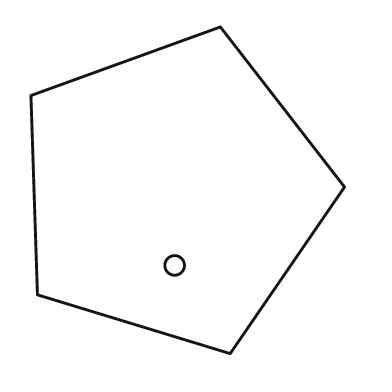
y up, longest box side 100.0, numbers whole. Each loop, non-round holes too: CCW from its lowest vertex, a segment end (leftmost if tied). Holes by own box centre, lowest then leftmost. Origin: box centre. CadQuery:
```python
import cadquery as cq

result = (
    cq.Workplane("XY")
    .moveTo(13.0, -50.0)
    .lineTo(48.0, 1.0)
    .lineTo(10.0, 50.0)
    .lineTo(-48.0, 29.0)
    .lineTo(-46.0, -32.0)
    .close()
    .moveTo(-4.0, -23.0)
    .circle(3.0)
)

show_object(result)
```